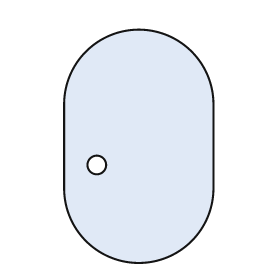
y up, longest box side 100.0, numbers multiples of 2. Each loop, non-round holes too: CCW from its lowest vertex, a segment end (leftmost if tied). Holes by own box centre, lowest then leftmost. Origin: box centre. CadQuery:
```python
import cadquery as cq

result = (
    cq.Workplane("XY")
    .moveTo(-32.0, -18.0)
    .threePointArc((0.0, -50.0), (32.0, -18.0))
    .lineTo(32.0, 18.0)
    .threePointArc((0.0, 50.0), (-32.0, 18.0))
    .close()
    .moveTo(-18.0, -8.0)
    .circle(4.0)
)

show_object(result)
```